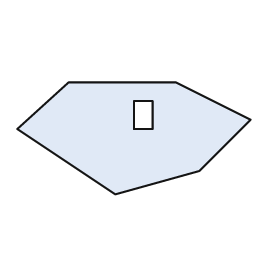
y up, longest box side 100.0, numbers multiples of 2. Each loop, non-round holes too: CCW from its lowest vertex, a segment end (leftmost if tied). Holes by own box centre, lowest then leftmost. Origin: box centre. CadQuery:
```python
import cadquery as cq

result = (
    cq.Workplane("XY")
    .moveTo(-8.0, -24.0)
    .lineTo(28.0, -14.0)
    .lineTo(50.0, 8.0)
    .lineTo(18.0, 24.0)
    .lineTo(-28.0, 24.0)
    .lineTo(-50.0, 4.0)
    .close()
    .moveTo(0.0, 4.0)
    .lineTo(8.0, 4.0)
    .lineTo(8.0, 16.0)
    .lineTo(0.0, 16.0)
    .close()
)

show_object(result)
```